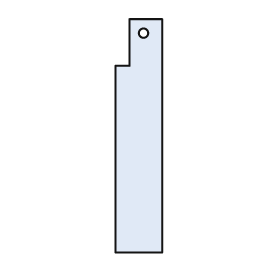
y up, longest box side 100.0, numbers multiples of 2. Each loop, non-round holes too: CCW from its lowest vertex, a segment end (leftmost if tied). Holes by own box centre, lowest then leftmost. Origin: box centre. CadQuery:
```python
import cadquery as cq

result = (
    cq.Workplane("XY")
    .moveTo(-10.0, -50.0)
    .lineTo(10.0, -50.0)
    .lineTo(10.0, 50.0)
    .lineTo(-4.0, 50.0)
    .lineTo(-4.0, 30.0)
    .lineTo(-10.0, 30.0)
    .close()
    .moveTo(2.0, 44.0)
    .circle(2.0)
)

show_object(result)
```